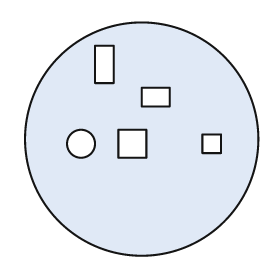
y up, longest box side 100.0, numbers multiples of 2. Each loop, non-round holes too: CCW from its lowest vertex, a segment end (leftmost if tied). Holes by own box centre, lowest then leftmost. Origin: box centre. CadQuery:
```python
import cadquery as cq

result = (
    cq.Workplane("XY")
    .moveTo(0.0, 0.0)
    .circle(50.0)
    .moveTo(-26.0, -2.0)
    .circle(6.0)
    .moveTo(-10.0, -8.0)
    .lineTo(2.0, -8.0)
    .lineTo(2.0, 4.0)
    .lineTo(-10.0, 4.0)
    .close()
    .moveTo(26.0, -6.0)
    .lineTo(34.0, -6.0)
    .lineTo(34.0, 2.0)
    .lineTo(26.0, 2.0)
    .close()
    .moveTo(0.0, 14.0)
    .lineTo(12.0, 14.0)
    .lineTo(12.0, 22.0)
    .lineTo(0.0, 22.0)
    .close()
    .moveTo(-20.0, 24.0)
    .lineTo(-12.0, 24.0)
    .lineTo(-12.0, 40.0)
    .lineTo(-20.0, 40.0)
    .close()
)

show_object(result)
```